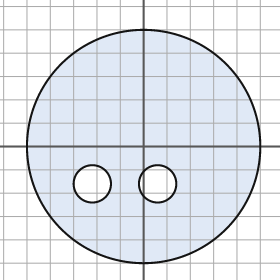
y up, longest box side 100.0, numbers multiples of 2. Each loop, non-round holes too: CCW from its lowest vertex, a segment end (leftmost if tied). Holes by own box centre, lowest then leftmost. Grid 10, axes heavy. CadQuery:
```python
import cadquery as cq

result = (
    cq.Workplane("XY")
    .moveTo(0.0, 0.0)
    .circle(50.0)
    .moveTo(-22.0, -16.0)
    .circle(8.0)
    .moveTo(6.0, -16.0)
    .circle(8.0)
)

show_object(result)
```